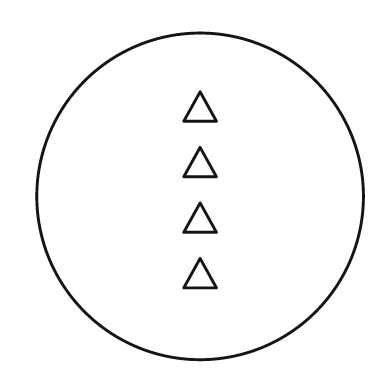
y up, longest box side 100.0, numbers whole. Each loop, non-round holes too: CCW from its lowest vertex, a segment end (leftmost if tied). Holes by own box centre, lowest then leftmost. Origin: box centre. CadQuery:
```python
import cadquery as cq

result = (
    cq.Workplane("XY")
    .moveTo(0.0, 0.0)
    .circle(50.0)
    .moveTo(-5.0, -28.0)
    .lineTo(5.0, -28.0)
    .lineTo(0.0, -19.0)
    .close()
    .moveTo(-5.0, -11.0)
    .lineTo(5.0, -11.0)
    .lineTo(0.0, -2.0)
    .close()
    .moveTo(-5.0, 6.0)
    .lineTo(5.0, 6.0)
    .lineTo(0.0, 15.0)
    .close()
    .moveTo(-5.0, 23.0)
    .lineTo(5.0, 23.0)
    .lineTo(0.0, 32.0)
    .close()
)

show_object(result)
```